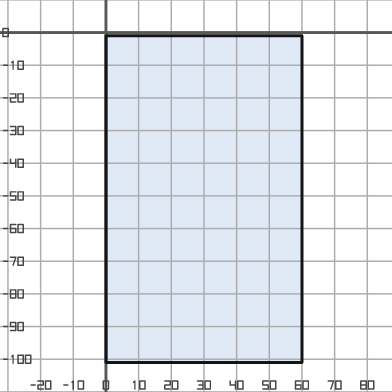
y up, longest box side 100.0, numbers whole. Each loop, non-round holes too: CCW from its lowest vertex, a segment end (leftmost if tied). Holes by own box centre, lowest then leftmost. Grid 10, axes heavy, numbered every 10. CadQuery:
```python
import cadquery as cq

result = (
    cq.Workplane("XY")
    .moveTo(0.0, -101.0)
    .lineTo(60.0, -101.0)
    .lineTo(60.0, -1.0)
    .lineTo(0.0, -1.0)
    .close()
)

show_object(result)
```